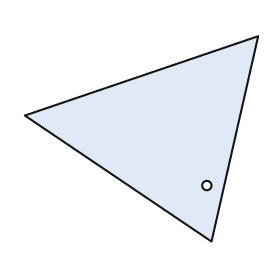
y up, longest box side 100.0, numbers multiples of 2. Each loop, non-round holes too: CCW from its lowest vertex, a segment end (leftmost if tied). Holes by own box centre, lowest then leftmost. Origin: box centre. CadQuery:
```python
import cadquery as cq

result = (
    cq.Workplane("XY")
    .moveTo(30.0, -44.0)
    .lineTo(50.0, 44.0)
    .lineTo(-50.0, 10.0)
    .close()
    .moveTo(28.0, -20.0)
    .circle(2.0)
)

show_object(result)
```